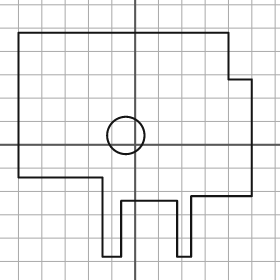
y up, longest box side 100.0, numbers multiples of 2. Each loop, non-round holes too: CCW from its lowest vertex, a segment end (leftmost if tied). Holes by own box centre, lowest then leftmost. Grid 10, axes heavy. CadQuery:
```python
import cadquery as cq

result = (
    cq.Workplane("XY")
    .moveTo(-14.0, -48.0)
    .lineTo(-6.0, -48.0)
    .lineTo(-6.0, -24.0)
    .lineTo(18.0, -24.0)
    .lineTo(18.0, -48.0)
    .lineTo(24.0, -48.0)
    .lineTo(24.0, -22.0)
    .lineTo(50.0, -22.0)
    .lineTo(50.0, 28.0)
    .lineTo(40.0, 28.0)
    .lineTo(40.0, 48.0)
    .lineTo(-50.0, 48.0)
    .lineTo(-50.0, -14.0)
    .lineTo(-14.0, -14.0)
    .close()
    .moveTo(-4.0, 4.0)
    .circle(8.0)
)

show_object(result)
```